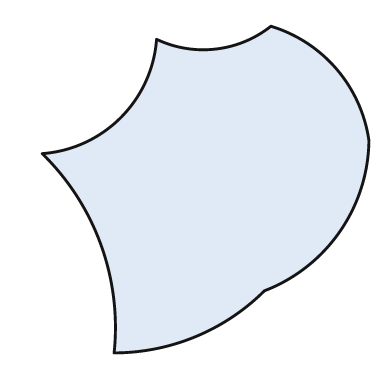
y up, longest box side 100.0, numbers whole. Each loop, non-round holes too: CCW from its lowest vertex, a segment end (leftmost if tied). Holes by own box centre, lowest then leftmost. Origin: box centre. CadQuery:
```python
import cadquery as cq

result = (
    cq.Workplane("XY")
    .moveTo(-28.0, -50.0)
    .threePointArc((-3.0, -45.0), (18.0, -31.0))
    .threePointArc((41.0, -13.0), (50.0, 15.0))
    .threePointArc((40.0, 37.0), (20.0, 50.0))
    .threePointArc((3.0, 43.0), (-15.0, 46.0))
    .threePointArc((-26.0, 22.0), (-50.0, 11.0))
    .threePointArc((-32.0, -17.0), (-28.0, -50.0))
    .close()
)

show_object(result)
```